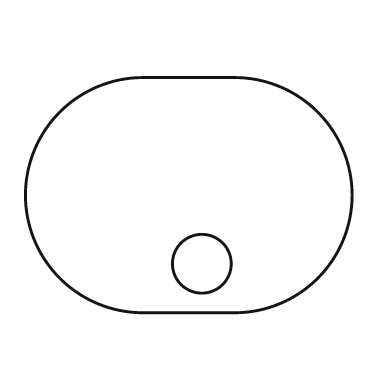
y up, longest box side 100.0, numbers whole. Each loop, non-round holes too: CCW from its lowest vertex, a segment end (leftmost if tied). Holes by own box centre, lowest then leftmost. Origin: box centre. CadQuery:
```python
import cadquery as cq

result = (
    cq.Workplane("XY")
    .moveTo(-14.0, -36.0)
    .lineTo(14.0, -36.0)
    .threePointArc((50.0, 0.0), (14.0, 36.0))
    .lineTo(-14.0, 36.0)
    .threePointArc((-50.0, 0.0), (-14.0, -36.0))
    .close()
    .moveTo(4.0, -21.0)
    .circle(9.0)
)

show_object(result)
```